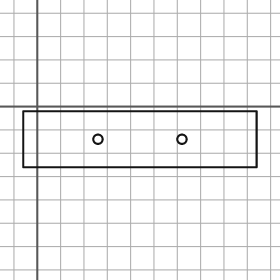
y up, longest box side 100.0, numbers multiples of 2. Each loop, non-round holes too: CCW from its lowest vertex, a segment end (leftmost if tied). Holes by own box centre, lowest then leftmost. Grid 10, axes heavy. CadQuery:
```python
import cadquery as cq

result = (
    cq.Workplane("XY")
    .moveTo(-6.0, -26.0)
    .lineTo(94.0, -26.0)
    .lineTo(94.0, -2.0)
    .lineTo(-6.0, -2.0)
    .close()
    .moveTo(26.0, -14.0)
    .circle(2.0)
    .moveTo(62.0, -14.0)
    .circle(2.0)
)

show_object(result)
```